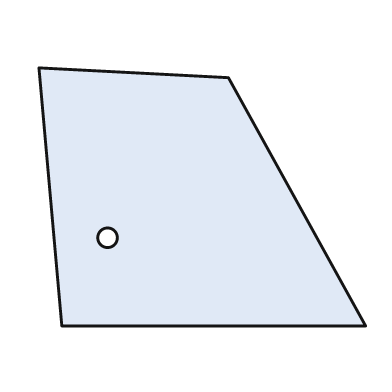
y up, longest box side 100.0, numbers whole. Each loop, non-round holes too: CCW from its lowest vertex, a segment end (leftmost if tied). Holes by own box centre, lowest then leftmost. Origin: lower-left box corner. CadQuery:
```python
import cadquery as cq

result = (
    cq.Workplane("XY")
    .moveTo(7.0, 0.0)
    .lineTo(100.0, 0.0)
    .lineTo(58.0, 76.0)
    .lineTo(0.0, 79.0)
    .close()
    .moveTo(21.0, 27.0)
    .circle(3.0)
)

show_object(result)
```